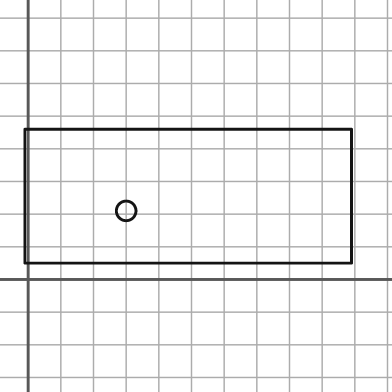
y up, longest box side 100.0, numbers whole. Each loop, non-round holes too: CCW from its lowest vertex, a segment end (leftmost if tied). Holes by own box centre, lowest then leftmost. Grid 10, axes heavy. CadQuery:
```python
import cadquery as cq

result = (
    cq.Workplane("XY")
    .moveTo(-1.0, 5.0)
    .lineTo(99.0, 5.0)
    .lineTo(99.0, 46.0)
    .lineTo(-1.0, 46.0)
    .close()
    .moveTo(30.0, 21.0)
    .circle(3.0)
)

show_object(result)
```